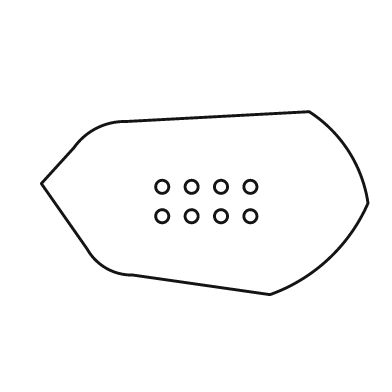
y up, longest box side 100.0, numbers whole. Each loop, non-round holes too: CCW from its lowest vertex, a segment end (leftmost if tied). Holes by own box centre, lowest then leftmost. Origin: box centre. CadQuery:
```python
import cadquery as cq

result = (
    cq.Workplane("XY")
    .moveTo(20.0, -28.0)
    .threePointArc((38.0, -17.0), (50.0, 0.0))
    .threePointArc((44.0, 16.0), (32.0, 28.0))
    .lineTo(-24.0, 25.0)
    .threePointArc((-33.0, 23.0), (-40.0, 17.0))
    .lineTo(-50.0, 6.0)
    .lineTo(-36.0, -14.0)
    .threePointArc((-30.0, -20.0), (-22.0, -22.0))
    .close()
    .moveTo(-13.0, -4.0)
    .circle(2.0)
    .moveTo(-4.0, -4.0)
    .circle(2.0)
    .moveTo(5.0, -4.0)
    .circle(2.0)
    .moveTo(14.0, -4.0)
    .circle(2.0)
    .moveTo(-13.0, 5.0)
    .circle(2.0)
    .moveTo(-4.0, 5.0)
    .circle(2.0)
    .moveTo(5.0, 5.0)
    .circle(2.0)
    .moveTo(14.0, 5.0)
    .circle(2.0)
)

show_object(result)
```